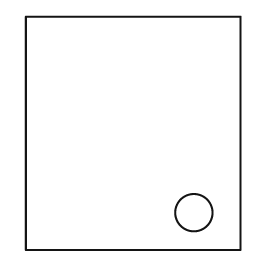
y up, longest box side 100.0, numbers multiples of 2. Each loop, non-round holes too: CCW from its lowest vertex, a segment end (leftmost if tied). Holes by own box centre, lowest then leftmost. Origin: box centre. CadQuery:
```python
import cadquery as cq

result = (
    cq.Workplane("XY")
    .moveTo(-46.0, -50.0)
    .lineTo(46.0, -50.0)
    .lineTo(46.0, 50.0)
    .lineTo(-46.0, 50.0)
    .close()
    .moveTo(26.0, -34.0)
    .circle(8.0)
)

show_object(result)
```